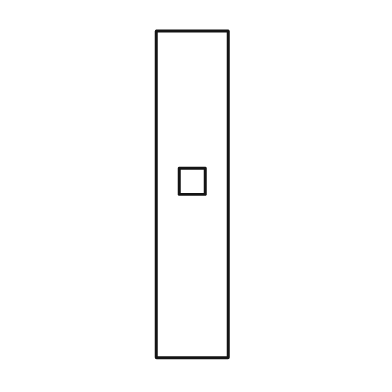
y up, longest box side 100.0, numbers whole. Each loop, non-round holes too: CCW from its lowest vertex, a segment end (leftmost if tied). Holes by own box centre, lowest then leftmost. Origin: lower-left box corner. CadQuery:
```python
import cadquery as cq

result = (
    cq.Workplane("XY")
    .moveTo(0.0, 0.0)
    .lineTo(22.0, 0.0)
    .lineTo(22.0, 100.0)
    .lineTo(0.0, 100.0)
    .close()
    .moveTo(7.0, 50.0)
    .lineTo(15.0, 50.0)
    .lineTo(15.0, 58.0)
    .lineTo(7.0, 58.0)
    .close()
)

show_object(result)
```